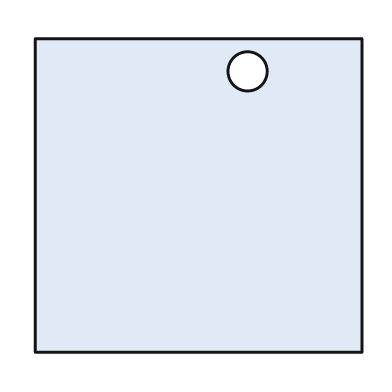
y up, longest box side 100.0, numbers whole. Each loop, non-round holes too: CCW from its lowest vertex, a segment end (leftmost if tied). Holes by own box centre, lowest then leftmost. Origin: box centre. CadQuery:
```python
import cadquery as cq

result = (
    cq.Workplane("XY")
    .moveTo(-50.0, -48.0)
    .lineTo(50.0, -48.0)
    .lineTo(50.0, 48.0)
    .lineTo(-50.0, 48.0)
    .close()
    .moveTo(15.0, 38.0)
    .circle(6.0)
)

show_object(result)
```